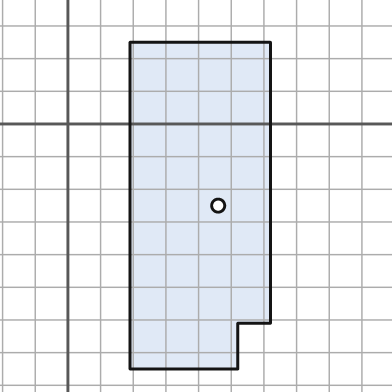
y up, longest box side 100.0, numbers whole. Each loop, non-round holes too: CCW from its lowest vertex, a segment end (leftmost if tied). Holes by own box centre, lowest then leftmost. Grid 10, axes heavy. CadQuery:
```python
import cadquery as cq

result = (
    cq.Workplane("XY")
    .moveTo(19.0, -75.0)
    .lineTo(52.0, -75.0)
    .lineTo(52.0, -61.0)
    .lineTo(62.0, -61.0)
    .lineTo(62.0, 25.0)
    .lineTo(19.0, 25.0)
    .close()
    .moveTo(46.0, -25.0)
    .circle(2.0)
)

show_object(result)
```